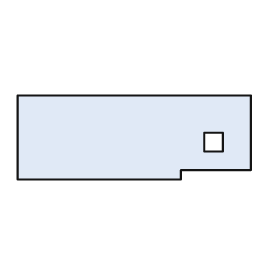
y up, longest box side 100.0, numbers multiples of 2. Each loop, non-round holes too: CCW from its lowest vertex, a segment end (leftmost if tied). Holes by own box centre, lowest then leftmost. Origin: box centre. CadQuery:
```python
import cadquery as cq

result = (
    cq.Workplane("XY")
    .moveTo(-50.0, -18.0)
    .lineTo(20.0, -18.0)
    .lineTo(20.0, -14.0)
    .lineTo(50.0, -14.0)
    .lineTo(50.0, 18.0)
    .lineTo(-50.0, 18.0)
    .close()
    .moveTo(30.0, -6.0)
    .lineTo(38.0, -6.0)
    .lineTo(38.0, 2.0)
    .lineTo(30.0, 2.0)
    .close()
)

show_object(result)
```